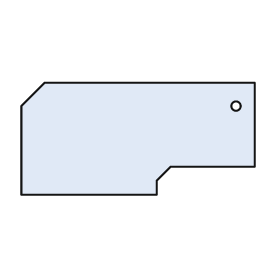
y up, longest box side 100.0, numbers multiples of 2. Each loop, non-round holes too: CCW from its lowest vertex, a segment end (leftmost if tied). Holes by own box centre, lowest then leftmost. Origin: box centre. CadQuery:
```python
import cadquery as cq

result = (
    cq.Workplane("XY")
    .moveTo(-50.0, -24.0)
    .lineTo(8.0, -24.0)
    .lineTo(8.0, -18.0)
    .lineTo(14.0, -12.0)
    .lineTo(50.0, -12.0)
    .lineTo(50.0, 24.0)
    .lineTo(-40.0, 24.0)
    .lineTo(-50.0, 14.0)
    .close()
    .moveTo(42.0, 14.0)
    .circle(2.0)
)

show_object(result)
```